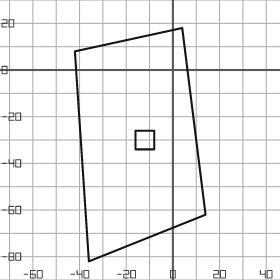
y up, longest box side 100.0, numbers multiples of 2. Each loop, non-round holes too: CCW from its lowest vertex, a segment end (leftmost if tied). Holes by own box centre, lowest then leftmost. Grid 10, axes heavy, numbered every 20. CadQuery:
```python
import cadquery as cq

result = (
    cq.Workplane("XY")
    .moveTo(-36.0, -82.0)
    .lineTo(14.0, -62.0)
    .lineTo(4.0, 18.0)
    .lineTo(-42.0, 8.0)
    .close()
    .moveTo(-16.0, -34.0)
    .lineTo(-8.0, -34.0)
    .lineTo(-8.0, -26.0)
    .lineTo(-16.0, -26.0)
    .close()
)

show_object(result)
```